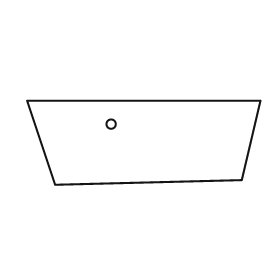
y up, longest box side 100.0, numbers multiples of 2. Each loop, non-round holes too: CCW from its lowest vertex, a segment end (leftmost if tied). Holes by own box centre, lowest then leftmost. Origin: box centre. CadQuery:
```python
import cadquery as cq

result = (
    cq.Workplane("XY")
    .moveTo(-38.0, -18.0)
    .lineTo(42.0, -16.0)
    .lineTo(50.0, 18.0)
    .lineTo(-50.0, 18.0)
    .close()
    .moveTo(-14.0, 8.0)
    .circle(2.0)
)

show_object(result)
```